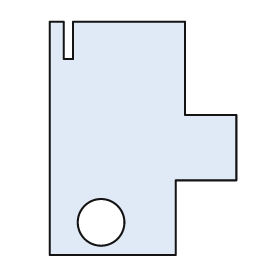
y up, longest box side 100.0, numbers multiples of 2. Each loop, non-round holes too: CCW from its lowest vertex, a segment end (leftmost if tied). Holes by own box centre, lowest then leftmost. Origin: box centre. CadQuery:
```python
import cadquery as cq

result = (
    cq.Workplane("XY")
    .moveTo(-40.0, -50.0)
    .lineTo(14.0, -50.0)
    .lineTo(14.0, -18.0)
    .lineTo(40.0, -18.0)
    .lineTo(40.0, 10.0)
    .lineTo(18.0, 10.0)
    .lineTo(18.0, 50.0)
    .lineTo(-30.0, 50.0)
    .lineTo(-30.0, 34.0)
    .lineTo(-34.0, 34.0)
    .lineTo(-34.0, 50.0)
    .lineTo(-40.0, 50.0)
    .close()
    .moveTo(-18.0, -36.0)
    .circle(10.0)
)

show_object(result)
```